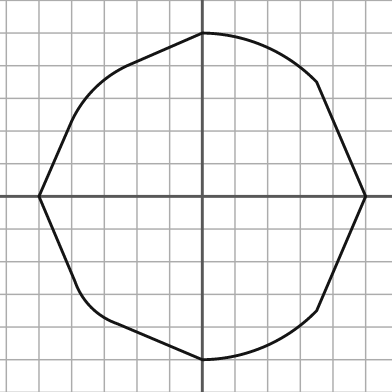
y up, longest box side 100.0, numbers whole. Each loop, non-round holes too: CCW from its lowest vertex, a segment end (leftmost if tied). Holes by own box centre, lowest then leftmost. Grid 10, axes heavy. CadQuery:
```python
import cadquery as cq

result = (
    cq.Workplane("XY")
    .moveTo(0.0, -50.0)
    .threePointArc((19.0, -46.0), (35.0, -35.0))
    .lineTo(50.0, 0.0)
    .lineTo(35.0, 35.0)
    .threePointArc((19.0, 46.0), (0.0, 50.0))
    .lineTo(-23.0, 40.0)
    .threePointArc((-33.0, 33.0), (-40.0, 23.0))
    .lineTo(-50.0, 0.0)
    .lineTo(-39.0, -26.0)
    .threePointArc((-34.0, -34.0), (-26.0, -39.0))
    .close()
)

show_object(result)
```